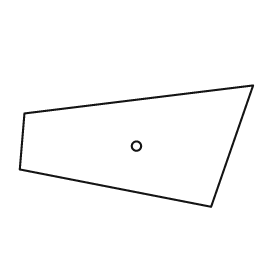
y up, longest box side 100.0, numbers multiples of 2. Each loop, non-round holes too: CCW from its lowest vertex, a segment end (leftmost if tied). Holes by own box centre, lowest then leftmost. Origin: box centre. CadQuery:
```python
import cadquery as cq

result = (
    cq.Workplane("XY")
    .moveTo(32.0, -26.0)
    .lineTo(50.0, 26.0)
    .lineTo(-48.0, 14.0)
    .lineTo(-50.0, -10.0)
    .close()
    .moveTo(0.0, 0.0)
    .circle(2.0)
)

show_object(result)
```